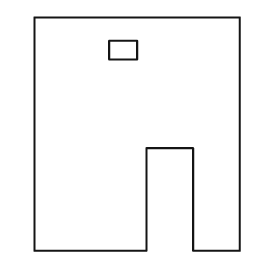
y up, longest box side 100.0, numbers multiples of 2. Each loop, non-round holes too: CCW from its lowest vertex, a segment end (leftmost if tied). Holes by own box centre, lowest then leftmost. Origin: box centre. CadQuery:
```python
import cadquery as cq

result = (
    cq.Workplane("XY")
    .moveTo(-44.0, -50.0)
    .lineTo(4.0, -50.0)
    .lineTo(4.0, -6.0)
    .lineTo(24.0, -6.0)
    .lineTo(24.0, -50.0)
    .lineTo(44.0, -50.0)
    .lineTo(44.0, 50.0)
    .lineTo(-44.0, 50.0)
    .close()
    .moveTo(-12.0, 32.0)
    .lineTo(0.0, 32.0)
    .lineTo(0.0, 40.0)
    .lineTo(-12.0, 40.0)
    .close()
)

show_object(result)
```